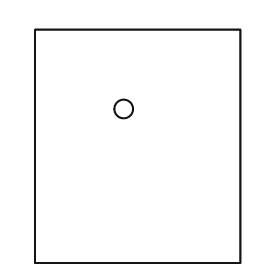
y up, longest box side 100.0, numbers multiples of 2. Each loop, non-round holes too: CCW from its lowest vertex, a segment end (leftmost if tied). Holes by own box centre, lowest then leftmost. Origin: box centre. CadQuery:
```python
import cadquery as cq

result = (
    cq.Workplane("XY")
    .moveTo(-44.0, -50.0)
    .lineTo(44.0, -50.0)
    .lineTo(44.0, 50.0)
    .lineTo(-44.0, 50.0)
    .close()
    .moveTo(-6.0, 16.0)
    .circle(4.0)
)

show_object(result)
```